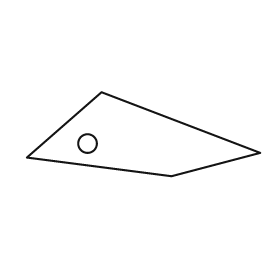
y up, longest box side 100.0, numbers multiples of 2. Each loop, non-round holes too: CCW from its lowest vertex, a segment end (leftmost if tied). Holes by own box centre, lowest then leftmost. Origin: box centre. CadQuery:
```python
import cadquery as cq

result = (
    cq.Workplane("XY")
    .moveTo(12.0, -18.0)
    .lineTo(50.0, -8.0)
    .lineTo(-18.0, 18.0)
    .lineTo(-50.0, -10.0)
    .close()
    .moveTo(-24.0, -4.0)
    .circle(4.0)
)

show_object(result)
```